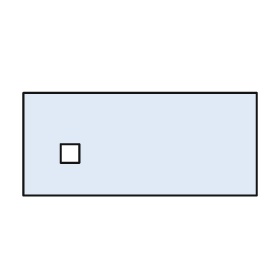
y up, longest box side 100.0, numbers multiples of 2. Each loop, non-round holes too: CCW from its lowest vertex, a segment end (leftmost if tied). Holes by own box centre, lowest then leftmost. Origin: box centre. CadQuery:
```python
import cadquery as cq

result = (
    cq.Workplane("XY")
    .moveTo(-50.0, -22.0)
    .lineTo(50.0, -22.0)
    .lineTo(50.0, 22.0)
    .lineTo(-50.0, 22.0)
    .close()
    .moveTo(-34.0, -8.0)
    .lineTo(-26.0, -8.0)
    .lineTo(-26.0, 0.0)
    .lineTo(-34.0, 0.0)
    .close()
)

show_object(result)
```